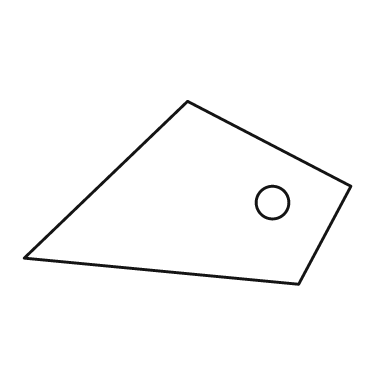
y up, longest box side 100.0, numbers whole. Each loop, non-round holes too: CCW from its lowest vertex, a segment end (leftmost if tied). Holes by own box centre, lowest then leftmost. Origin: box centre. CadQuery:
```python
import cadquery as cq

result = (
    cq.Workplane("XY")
    .moveTo(34.0, -28.0)
    .lineTo(50.0, 2.0)
    .lineTo(0.0, 28.0)
    .lineTo(-50.0, -20.0)
    .close()
    .moveTo(26.0, -3.0)
    .circle(5.0)
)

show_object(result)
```